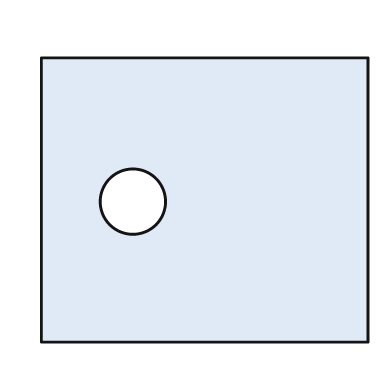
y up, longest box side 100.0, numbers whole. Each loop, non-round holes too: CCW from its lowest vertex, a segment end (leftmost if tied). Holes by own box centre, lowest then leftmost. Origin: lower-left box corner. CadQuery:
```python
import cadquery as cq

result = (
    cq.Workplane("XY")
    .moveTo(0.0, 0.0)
    .lineTo(100.0, 0.0)
    .lineTo(100.0, 87.0)
    .lineTo(0.0, 87.0)
    .close()
    .moveTo(28.0, 43.0)
    .circle(10.0)
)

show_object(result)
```